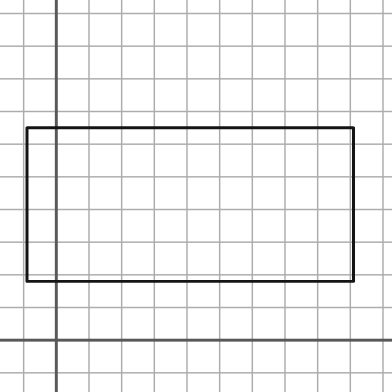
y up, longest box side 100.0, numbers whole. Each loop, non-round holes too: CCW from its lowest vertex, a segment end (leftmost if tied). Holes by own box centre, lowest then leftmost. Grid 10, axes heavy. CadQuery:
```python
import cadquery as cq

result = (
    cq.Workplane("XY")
    .moveTo(-9.0, 18.0)
    .lineTo(91.0, 18.0)
    .lineTo(91.0, 65.0)
    .lineTo(-9.0, 65.0)
    .close()
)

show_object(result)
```